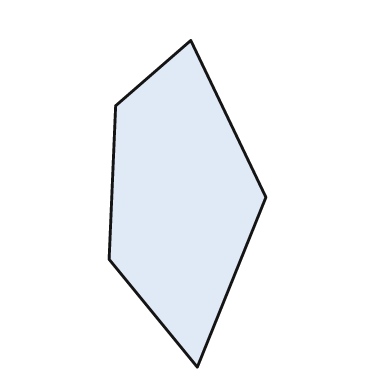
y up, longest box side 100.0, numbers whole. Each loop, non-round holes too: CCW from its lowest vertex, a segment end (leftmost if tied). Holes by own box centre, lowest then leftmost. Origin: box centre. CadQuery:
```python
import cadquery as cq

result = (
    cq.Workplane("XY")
    .moveTo(3.0, -50.0)
    .lineTo(24.0, 2.0)
    .lineTo(1.0, 50.0)
    .lineTo(-22.0, 30.0)
    .lineTo(-24.0, -17.0)
    .close()
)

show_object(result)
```